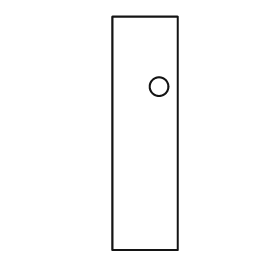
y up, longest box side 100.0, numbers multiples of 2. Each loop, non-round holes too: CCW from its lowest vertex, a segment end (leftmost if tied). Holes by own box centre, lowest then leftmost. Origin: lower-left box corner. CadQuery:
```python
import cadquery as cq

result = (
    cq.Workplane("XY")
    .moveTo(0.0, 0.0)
    .lineTo(28.0, 0.0)
    .lineTo(28.0, 100.0)
    .lineTo(0.0, 100.0)
    .close()
    .moveTo(20.0, 70.0)
    .circle(4.0)
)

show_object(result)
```